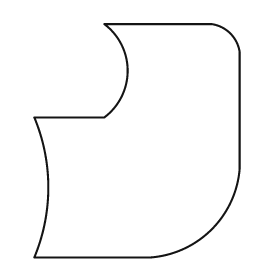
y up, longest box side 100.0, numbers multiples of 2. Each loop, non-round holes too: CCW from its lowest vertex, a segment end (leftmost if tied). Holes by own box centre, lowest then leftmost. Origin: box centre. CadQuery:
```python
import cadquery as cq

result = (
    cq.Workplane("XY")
    .moveTo(-44.0, -50.0)
    .lineTo(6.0, -50.0)
    .threePointArc((32.0, -38.0), (44.0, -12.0))
    .lineTo(44.0, 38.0)
    .threePointArc((40.0, 46.0), (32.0, 50.0))
    .lineTo(-14.0, 50.0)
    .threePointArc((-4.0, 30.0), (-14.0, 10.0))
    .lineTo(-44.0, 10.0)
    .threePointArc((-38.0, -20.0), (-44.0, -50.0))
    .close()
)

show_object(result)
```